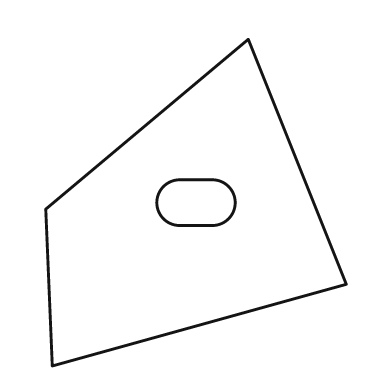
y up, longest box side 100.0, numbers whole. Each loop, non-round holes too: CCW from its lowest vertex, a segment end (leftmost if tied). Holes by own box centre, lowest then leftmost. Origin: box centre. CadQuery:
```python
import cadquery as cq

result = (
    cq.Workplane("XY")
    .moveTo(-44.0, -50.0)
    .lineTo(46.0, -25.0)
    .lineTo(16.0, 50.0)
    .lineTo(-46.0, -2.0)
    .close()
    .moveTo(-5.0, -7.0)
    .lineTo(5.0, -7.0)
    .threePointArc((12.0, 0.0), (5.0, 7.0))
    .lineTo(-5.0, 7.0)
    .threePointArc((-12.0, 0.0), (-5.0, -7.0))
    .close()
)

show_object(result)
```